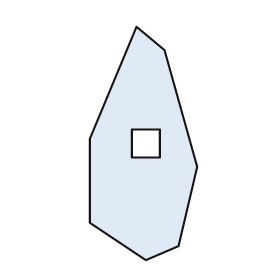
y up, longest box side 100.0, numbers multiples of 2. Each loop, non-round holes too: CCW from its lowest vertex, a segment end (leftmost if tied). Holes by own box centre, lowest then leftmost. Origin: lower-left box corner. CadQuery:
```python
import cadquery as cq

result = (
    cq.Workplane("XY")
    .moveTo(24.0, 0.0)
    .lineTo(38.0, 6.0)
    .lineTo(46.0, 40.0)
    .lineTo(32.0, 90.0)
    .lineTo(20.0, 100.0)
    .lineTo(0.0, 52.0)
    .lineTo(0.0, 16.0)
    .close()
    .moveTo(18.0, 44.0)
    .lineTo(30.0, 44.0)
    .lineTo(30.0, 56.0)
    .lineTo(18.0, 56.0)
    .close()
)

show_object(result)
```